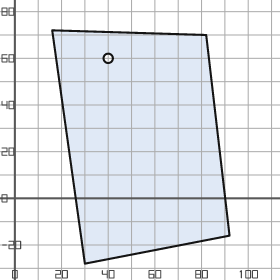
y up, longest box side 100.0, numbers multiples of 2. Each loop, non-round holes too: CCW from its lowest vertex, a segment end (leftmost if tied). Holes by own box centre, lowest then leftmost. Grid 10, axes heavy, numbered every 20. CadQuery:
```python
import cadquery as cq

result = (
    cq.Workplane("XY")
    .moveTo(30.0, -28.0)
    .lineTo(92.0, -16.0)
    .lineTo(82.0, 70.0)
    .lineTo(16.0, 72.0)
    .close()
    .moveTo(40.0, 60.0)
    .circle(2.0)
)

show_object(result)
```